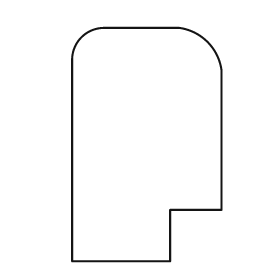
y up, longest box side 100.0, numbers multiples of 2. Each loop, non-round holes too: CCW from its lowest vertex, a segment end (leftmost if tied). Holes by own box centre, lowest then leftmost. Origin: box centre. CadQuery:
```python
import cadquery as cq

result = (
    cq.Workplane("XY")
    .moveTo(-32.0, -50.0)
    .lineTo(10.0, -50.0)
    .lineTo(10.0, -28.0)
    .lineTo(32.0, -28.0)
    .lineTo(32.0, 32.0)
    .threePointArc((26.0, 44.0), (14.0, 50.0))
    .lineTo(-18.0, 50.0)
    .threePointArc((-28.0, 46.0), (-32.0, 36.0))
    .close()
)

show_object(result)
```